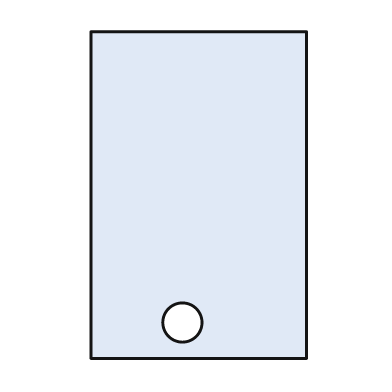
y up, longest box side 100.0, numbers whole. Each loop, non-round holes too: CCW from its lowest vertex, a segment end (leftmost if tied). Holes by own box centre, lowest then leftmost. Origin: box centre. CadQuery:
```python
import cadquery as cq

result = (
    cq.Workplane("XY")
    .moveTo(-33.0, -50.0)
    .lineTo(33.0, -50.0)
    .lineTo(33.0, 50.0)
    .lineTo(-33.0, 50.0)
    .close()
    .moveTo(-5.0, -39.0)
    .circle(6.0)
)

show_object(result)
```